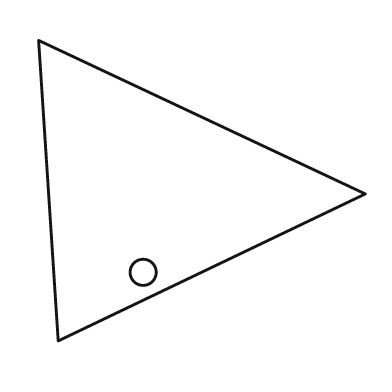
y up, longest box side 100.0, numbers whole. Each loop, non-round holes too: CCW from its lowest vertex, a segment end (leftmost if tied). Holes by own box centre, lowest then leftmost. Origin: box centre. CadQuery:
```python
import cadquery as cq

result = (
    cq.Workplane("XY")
    .moveTo(-44.0, -46.0)
    .lineTo(50.0, -1.0)
    .lineTo(-50.0, 46.0)
    .close()
    .moveTo(-18.0, -25.0)
    .circle(4.0)
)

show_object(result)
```